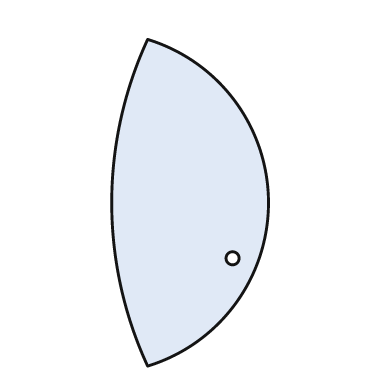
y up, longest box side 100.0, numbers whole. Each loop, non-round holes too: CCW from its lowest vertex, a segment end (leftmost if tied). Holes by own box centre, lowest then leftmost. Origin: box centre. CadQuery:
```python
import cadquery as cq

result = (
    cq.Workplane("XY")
    .moveTo(-13.0, -50.0)
    .threePointArc((24.0, 0.0), (-13.0, 50.0))
    .threePointArc((-24.0, 0.0), (-13.0, -50.0))
    .close()
    .moveTo(13.0, -17.0)
    .circle(2.0)
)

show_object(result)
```